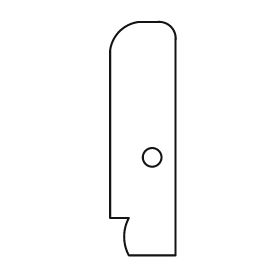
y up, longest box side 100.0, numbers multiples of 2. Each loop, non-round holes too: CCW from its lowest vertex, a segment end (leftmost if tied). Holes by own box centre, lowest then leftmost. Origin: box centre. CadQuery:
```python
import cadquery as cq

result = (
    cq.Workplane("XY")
    .moveTo(-6.0, -50.0)
    .lineTo(14.0, -50.0)
    .lineTo(14.0, 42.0)
    .threePointArc((12.0, 48.0), (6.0, 50.0))
    .lineTo(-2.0, 50.0)
    .threePointArc((-10.0, 46.0), (-14.0, 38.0))
    .lineTo(-14.0, -34.0)
    .lineTo(-6.0, -34.0)
    .threePointArc((-8.0, -42.0), (-6.0, -50.0))
    .close()
    .moveTo(4.0, -8.0)
    .circle(4.0)
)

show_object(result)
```